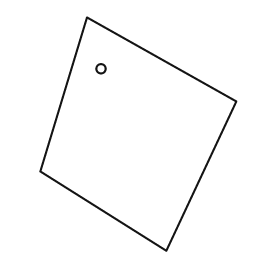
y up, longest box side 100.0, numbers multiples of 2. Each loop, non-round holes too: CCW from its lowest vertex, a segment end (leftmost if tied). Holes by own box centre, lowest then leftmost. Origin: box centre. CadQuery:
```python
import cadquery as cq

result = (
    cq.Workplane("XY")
    .moveTo(12.0, -50.0)
    .lineTo(42.0, 14.0)
    .lineTo(-22.0, 50.0)
    .lineTo(-42.0, -16.0)
    .close()
    .moveTo(-16.0, 28.0)
    .circle(2.0)
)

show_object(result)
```